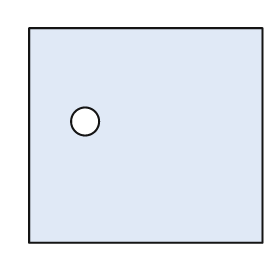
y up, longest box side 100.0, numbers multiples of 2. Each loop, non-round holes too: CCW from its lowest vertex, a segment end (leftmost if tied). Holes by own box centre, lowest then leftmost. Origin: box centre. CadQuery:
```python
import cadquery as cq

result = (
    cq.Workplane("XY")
    .moveTo(-50.0, -46.0)
    .lineTo(50.0, -46.0)
    .lineTo(50.0, 46.0)
    .lineTo(-50.0, 46.0)
    .close()
    .moveTo(-26.0, 6.0)
    .circle(6.0)
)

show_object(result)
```